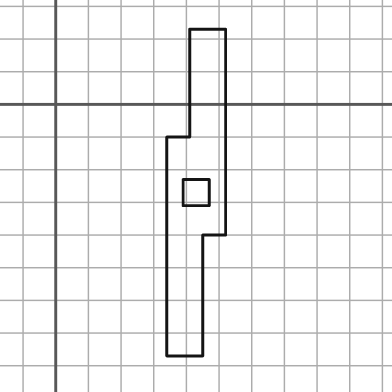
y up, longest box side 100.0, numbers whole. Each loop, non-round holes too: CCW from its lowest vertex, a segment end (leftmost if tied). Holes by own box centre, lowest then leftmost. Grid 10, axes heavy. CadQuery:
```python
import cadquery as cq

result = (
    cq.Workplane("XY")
    .moveTo(34.0, -77.0)
    .lineTo(45.0, -77.0)
    .lineTo(45.0, -40.0)
    .lineTo(52.0, -40.0)
    .lineTo(52.0, 23.0)
    .lineTo(41.0, 23.0)
    .lineTo(41.0, -10.0)
    .lineTo(34.0, -10.0)
    .close()
    .moveTo(39.0, -31.0)
    .lineTo(47.0, -31.0)
    .lineTo(47.0, -23.0)
    .lineTo(39.0, -23.0)
    .close()
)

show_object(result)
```